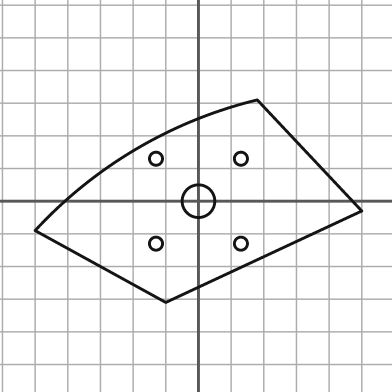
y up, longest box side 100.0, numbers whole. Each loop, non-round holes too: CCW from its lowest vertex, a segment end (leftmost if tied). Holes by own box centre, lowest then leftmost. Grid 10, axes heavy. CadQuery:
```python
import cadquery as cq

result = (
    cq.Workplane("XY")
    .moveTo(-10.0, -31.0)
    .lineTo(50.0, -3.0)
    .lineTo(18.0, 31.0)
    .threePointArc((-19.0, 16.0), (-50.0, -9.0))
    .close()
    .moveTo(-13.0, -13.0)
    .circle(2.0)
    .moveTo(13.0, -13.0)
    .circle(2.0)
    .moveTo(0.0, 0.0)
    .circle(5.0)
    .moveTo(-13.0, 13.0)
    .circle(2.0)
    .moveTo(13.0, 13.0)
    .circle(2.0)
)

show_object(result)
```